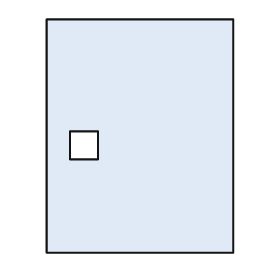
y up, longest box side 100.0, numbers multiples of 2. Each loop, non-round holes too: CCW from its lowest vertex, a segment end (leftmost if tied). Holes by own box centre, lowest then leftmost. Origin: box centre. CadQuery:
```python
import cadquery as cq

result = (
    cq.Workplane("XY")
    .moveTo(-40.0, -50.0)
    .lineTo(40.0, -50.0)
    .lineTo(40.0, 50.0)
    .lineTo(-40.0, 50.0)
    .close()
    .moveTo(-30.0, -10.0)
    .lineTo(-18.0, -10.0)
    .lineTo(-18.0, 2.0)
    .lineTo(-30.0, 2.0)
    .close()
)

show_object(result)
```